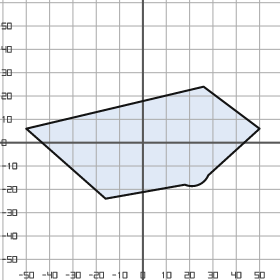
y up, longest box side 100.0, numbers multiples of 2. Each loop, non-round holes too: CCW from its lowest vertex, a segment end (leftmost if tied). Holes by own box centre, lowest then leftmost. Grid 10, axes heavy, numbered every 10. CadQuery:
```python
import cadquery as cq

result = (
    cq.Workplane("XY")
    .moveTo(-16.0, -24.0)
    .lineTo(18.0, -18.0)
    .threePointArc((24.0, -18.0), (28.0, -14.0))
    .lineTo(50.0, 6.0)
    .lineTo(26.0, 24.0)
    .lineTo(-50.0, 6.0)
    .close()
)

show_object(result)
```